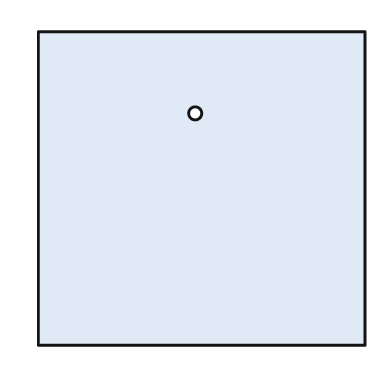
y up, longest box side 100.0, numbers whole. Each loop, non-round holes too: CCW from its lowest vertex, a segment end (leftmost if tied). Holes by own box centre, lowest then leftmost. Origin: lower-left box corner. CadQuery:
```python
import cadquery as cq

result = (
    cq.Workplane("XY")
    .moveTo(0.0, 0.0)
    .lineTo(100.0, 0.0)
    .lineTo(100.0, 96.0)
    .lineTo(0.0, 96.0)
    .close()
    .moveTo(48.0, 71.0)
    .circle(2.0)
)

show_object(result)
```